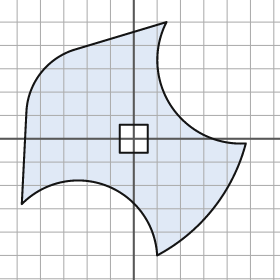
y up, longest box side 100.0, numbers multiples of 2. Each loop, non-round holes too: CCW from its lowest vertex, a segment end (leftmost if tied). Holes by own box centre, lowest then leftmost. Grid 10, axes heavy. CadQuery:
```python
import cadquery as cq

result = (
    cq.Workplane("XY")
    .moveTo(10.0, -50.0)
    .threePointArc((34.0, -30.0), (48.0, -2.0))
    .threePointArc((16.0, 14.0), (14.0, 50.0))
    .lineTo(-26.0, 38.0)
    .threePointArc((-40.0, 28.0), (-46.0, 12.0))
    .lineTo(-48.0, -28.0)
    .threePointArc((-12.0, -20.0), (10.0, -50.0))
    .close()
    .moveTo(-6.0, -6.0)
    .lineTo(6.0, -6.0)
    .lineTo(6.0, 6.0)
    .lineTo(-6.0, 6.0)
    .close()
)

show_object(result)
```